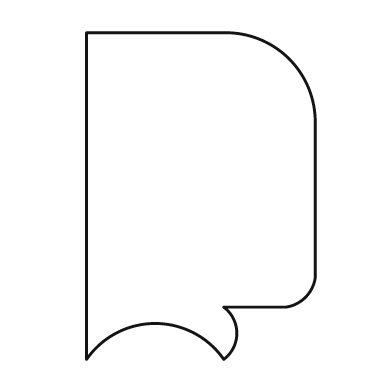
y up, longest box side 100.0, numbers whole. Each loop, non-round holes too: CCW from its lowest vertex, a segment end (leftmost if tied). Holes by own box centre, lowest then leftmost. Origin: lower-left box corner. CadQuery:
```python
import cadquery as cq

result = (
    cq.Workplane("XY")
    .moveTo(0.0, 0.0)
    .threePointArc((21.0, 11.0), (42.0, 0.0))
    .threePointArc((46.0, 8.0), (42.0, 16.0))
    .lineTo(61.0, 16.0)
    .threePointArc((67.0, 19.0), (70.0, 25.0))
    .lineTo(70.0, 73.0)
    .threePointArc((62.0, 92.0), (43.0, 100.0))
    .lineTo(0.0, 100.0)
    .close()
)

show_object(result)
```